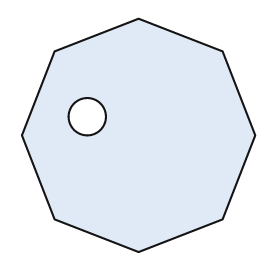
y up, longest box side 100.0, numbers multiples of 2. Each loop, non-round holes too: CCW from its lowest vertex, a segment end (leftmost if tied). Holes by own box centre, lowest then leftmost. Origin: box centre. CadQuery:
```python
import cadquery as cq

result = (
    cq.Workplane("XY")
    .moveTo(0.0, -50.0)
    .lineTo(36.0, -36.0)
    .lineTo(50.0, 0.0)
    .lineTo(36.0, 36.0)
    .lineTo(0.0, 50.0)
    .lineTo(-36.0, 36.0)
    .lineTo(-50.0, 0.0)
    .lineTo(-36.0, -36.0)
    .close()
    .moveTo(-22.0, 8.0)
    .circle(8.0)
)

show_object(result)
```